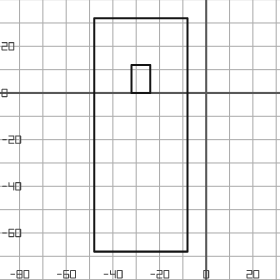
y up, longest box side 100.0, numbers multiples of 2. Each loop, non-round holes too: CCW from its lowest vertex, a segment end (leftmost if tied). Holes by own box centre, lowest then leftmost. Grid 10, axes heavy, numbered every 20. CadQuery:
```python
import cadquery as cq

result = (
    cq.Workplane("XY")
    .moveTo(-48.0, -68.0)
    .lineTo(-8.0, -68.0)
    .lineTo(-8.0, 32.0)
    .lineTo(-48.0, 32.0)
    .close()
    .moveTo(-32.0, 0.0)
    .lineTo(-24.0, 0.0)
    .lineTo(-24.0, 12.0)
    .lineTo(-32.0, 12.0)
    .close()
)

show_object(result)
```